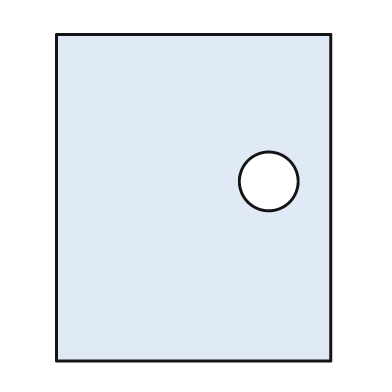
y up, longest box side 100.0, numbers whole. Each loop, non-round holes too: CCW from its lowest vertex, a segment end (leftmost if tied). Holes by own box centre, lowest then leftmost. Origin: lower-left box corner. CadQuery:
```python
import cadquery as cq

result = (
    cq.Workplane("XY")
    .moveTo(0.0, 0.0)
    .lineTo(84.0, 0.0)
    .lineTo(84.0, 100.0)
    .lineTo(0.0, 100.0)
    .close()
    .moveTo(65.0, 55.0)
    .circle(9.0)
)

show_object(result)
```